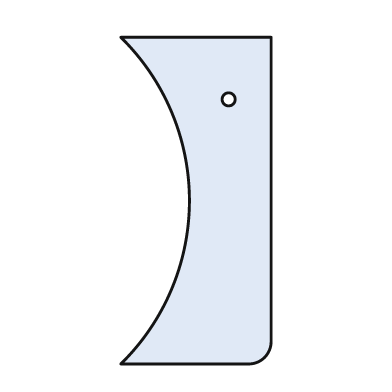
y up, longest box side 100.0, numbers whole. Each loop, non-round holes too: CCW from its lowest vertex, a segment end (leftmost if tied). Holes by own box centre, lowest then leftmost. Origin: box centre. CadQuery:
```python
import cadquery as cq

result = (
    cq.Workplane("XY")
    .moveTo(-23.0, -50.0)
    .lineTo(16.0, -50.0)
    .threePointArc((21.0, -48.0), (23.0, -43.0))
    .lineTo(23.0, 50.0)
    .lineTo(-23.0, 50.0)
    .threePointArc((-2.0, 0.0), (-23.0, -50.0))
    .close()
    .moveTo(10.0, 31.0)
    .circle(2.0)
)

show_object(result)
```